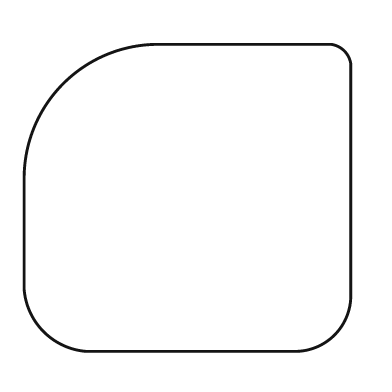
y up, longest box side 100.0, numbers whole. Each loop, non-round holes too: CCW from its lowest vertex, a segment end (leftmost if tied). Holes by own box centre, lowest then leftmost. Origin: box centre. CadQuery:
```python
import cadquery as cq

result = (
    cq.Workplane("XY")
    .moveTo(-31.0, -47.0)
    .lineTo(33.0, -47.0)
    .threePointArc((45.0, -42.0), (50.0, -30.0))
    .lineTo(50.0, 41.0)
    .threePointArc((48.0, 45.0), (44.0, 47.0))
    .lineTo(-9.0, 47.0)
    .threePointArc((-38.0, 35.0), (-50.0, 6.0))
    .lineTo(-50.0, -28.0)
    .threePointArc((-44.0, -41.0), (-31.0, -47.0))
    .close()
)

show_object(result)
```